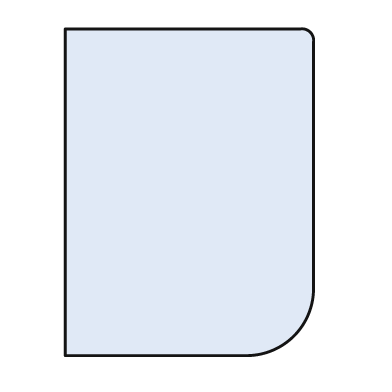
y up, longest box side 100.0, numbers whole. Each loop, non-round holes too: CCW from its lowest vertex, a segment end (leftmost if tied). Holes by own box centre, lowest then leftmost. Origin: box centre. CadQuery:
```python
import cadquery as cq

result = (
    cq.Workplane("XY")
    .moveTo(-38.0, -50.0)
    .lineTo(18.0, -50.0)
    .threePointArc((32.0, -44.0), (38.0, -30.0))
    .lineTo(38.0, 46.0)
    .threePointArc((37.0, 49.0), (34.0, 50.0))
    .lineTo(-38.0, 50.0)
    .close()
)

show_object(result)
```